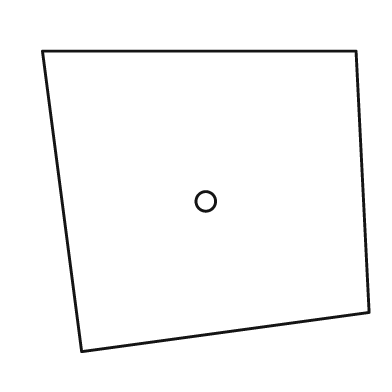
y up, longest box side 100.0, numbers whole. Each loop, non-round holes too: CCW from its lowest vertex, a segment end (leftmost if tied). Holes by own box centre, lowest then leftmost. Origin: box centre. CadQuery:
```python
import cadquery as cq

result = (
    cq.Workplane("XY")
    .moveTo(-38.0, -46.0)
    .lineTo(50.0, -34.0)
    .lineTo(46.0, 46.0)
    .lineTo(-50.0, 46.0)
    .close()
    .moveTo(0.0, 0.0)
    .circle(3.0)
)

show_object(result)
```